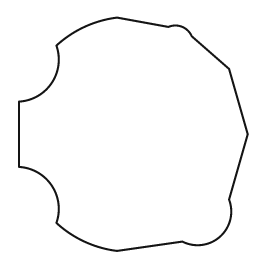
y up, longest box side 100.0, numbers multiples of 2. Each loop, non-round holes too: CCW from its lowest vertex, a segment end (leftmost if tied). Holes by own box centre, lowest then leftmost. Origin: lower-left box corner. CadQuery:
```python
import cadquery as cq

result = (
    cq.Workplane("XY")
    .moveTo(42.0, 0.0)
    .lineTo(70.0, 4.0)
    .threePointArc((86.0, 6.0), (90.0, 22.0))
    .lineTo(98.0, 50.0)
    .lineTo(90.0, 78.0)
    .lineTo(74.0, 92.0)
    .threePointArc((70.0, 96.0), (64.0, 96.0))
    .lineTo(42.0, 100.0)
    .threePointArc((28.0, 96.0), (16.0, 88.0))
    .threePointArc((14.0, 72.0), (0.0, 64.0))
    .lineTo(0.0, 36.0)
    .threePointArc((14.0, 28.0), (16.0, 12.0))
    .threePointArc((28.0, 4.0), (42.0, 0.0))
    .close()
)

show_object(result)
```